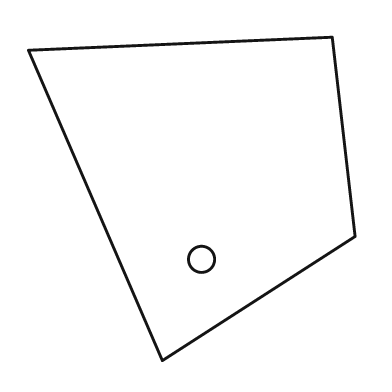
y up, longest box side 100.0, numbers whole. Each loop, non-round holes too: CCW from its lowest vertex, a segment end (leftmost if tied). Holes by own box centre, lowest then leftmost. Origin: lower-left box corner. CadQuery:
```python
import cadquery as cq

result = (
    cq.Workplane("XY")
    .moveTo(41.0, 0.0)
    .lineTo(100.0, 38.0)
    .lineTo(93.0, 99.0)
    .lineTo(0.0, 95.0)
    .close()
    .moveTo(53.0, 31.0)
    .circle(4.0)
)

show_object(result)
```